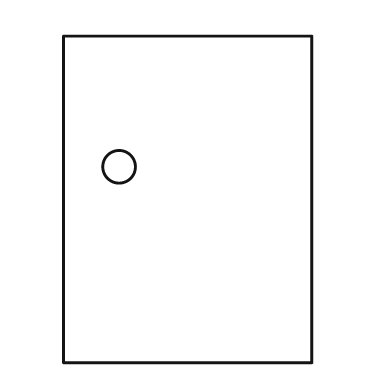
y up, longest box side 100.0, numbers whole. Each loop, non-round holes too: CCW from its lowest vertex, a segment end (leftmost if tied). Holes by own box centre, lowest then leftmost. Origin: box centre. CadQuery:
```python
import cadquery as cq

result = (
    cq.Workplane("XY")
    .moveTo(-38.0, -50.0)
    .lineTo(38.0, -50.0)
    .lineTo(38.0, 50.0)
    .lineTo(-38.0, 50.0)
    .close()
    .moveTo(-21.0, 10.0)
    .circle(5.0)
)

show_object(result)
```